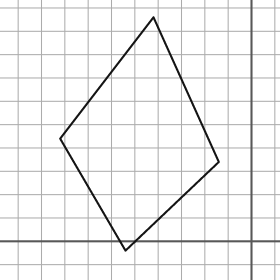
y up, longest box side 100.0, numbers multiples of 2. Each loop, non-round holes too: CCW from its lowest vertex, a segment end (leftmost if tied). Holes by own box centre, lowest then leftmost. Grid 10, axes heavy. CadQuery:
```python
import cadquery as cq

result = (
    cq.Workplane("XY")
    .moveTo(-54.0, -4.0)
    .lineTo(-14.0, 34.0)
    .lineTo(-42.0, 96.0)
    .lineTo(-82.0, 44.0)
    .close()
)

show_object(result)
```